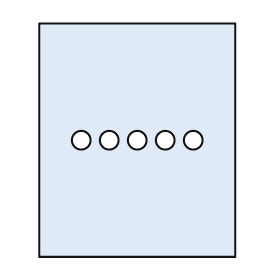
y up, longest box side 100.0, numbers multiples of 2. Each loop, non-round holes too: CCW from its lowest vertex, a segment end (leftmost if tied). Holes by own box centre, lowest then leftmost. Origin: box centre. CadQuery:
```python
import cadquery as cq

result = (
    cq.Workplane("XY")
    .moveTo(-42.0, -50.0)
    .lineTo(42.0, -50.0)
    .lineTo(42.0, 50.0)
    .lineTo(-42.0, 50.0)
    .close()
    .moveTo(-24.0, 0.0)
    .circle(4.0)
    .moveTo(-12.0, 0.0)
    .circle(4.0)
    .moveTo(0.0, 0.0)
    .circle(4.0)
    .moveTo(12.0, 0.0)
    .circle(4.0)
    .moveTo(24.0, 0.0)
    .circle(4.0)
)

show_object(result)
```